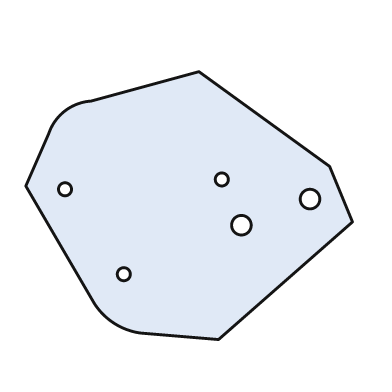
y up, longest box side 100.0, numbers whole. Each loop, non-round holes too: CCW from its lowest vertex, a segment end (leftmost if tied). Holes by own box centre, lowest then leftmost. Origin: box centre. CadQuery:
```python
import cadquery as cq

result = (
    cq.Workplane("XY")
    .moveTo(9.0, -41.0)
    .lineTo(50.0, -5.0)
    .lineTo(43.0, 12.0)
    .lineTo(3.0, 41.0)
    .lineTo(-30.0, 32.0)
    .threePointArc((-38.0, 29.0), (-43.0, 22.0))
    .lineTo(-50.0, 6.0)
    .lineTo(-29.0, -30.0)
    .threePointArc((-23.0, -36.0), (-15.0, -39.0))
    .close()
    .moveTo(-20.0, -21.0)
    .circle(2.0)
    .moveTo(16.0, -6.0)
    .circle(3.0)
    .moveTo(37.0, 2.0)
    .circle(3.0)
    .moveTo(-38.0, 5.0)
    .circle(2.0)
    .moveTo(10.0, 8.0)
    .circle(2.0)
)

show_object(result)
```